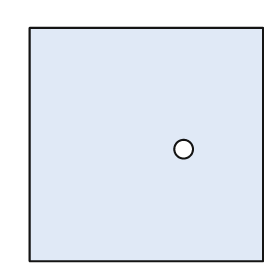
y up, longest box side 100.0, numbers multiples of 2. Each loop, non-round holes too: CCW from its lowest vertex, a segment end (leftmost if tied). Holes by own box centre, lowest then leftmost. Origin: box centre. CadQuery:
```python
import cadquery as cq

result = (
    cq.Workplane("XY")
    .moveTo(-50.0, -50.0)
    .lineTo(50.0, -50.0)
    .lineTo(50.0, 50.0)
    .lineTo(-50.0, 50.0)
    .close()
    .moveTo(16.0, -2.0)
    .circle(4.0)
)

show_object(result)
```